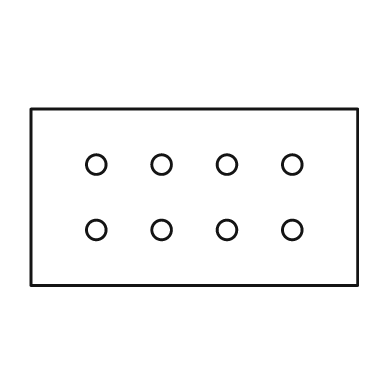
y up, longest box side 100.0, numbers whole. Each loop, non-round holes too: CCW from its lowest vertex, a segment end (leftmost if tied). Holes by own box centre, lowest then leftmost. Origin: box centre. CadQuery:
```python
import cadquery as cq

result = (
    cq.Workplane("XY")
    .moveTo(-50.0, -27.0)
    .lineTo(50.0, -27.0)
    .lineTo(50.0, 27.0)
    .lineTo(-50.0, 27.0)
    .close()
    .moveTo(-30.0, -10.0)
    .circle(3.0)
    .moveTo(-10.0, -10.0)
    .circle(3.0)
    .moveTo(10.0, -10.0)
    .circle(3.0)
    .moveTo(30.0, -10.0)
    .circle(3.0)
    .moveTo(-30.0, 10.0)
    .circle(3.0)
    .moveTo(-10.0, 10.0)
    .circle(3.0)
    .moveTo(10.0, 10.0)
    .circle(3.0)
    .moveTo(30.0, 10.0)
    .circle(3.0)
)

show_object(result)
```